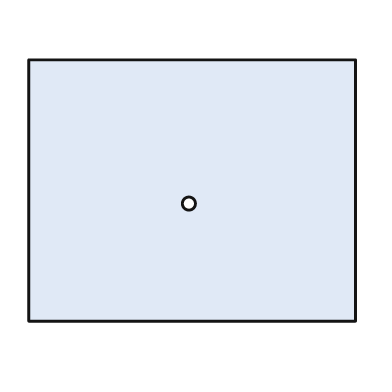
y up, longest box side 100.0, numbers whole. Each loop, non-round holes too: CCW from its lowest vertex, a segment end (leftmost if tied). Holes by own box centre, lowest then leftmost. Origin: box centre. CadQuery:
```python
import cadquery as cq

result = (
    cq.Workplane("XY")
    .moveTo(-50.0, -40.0)
    .lineTo(50.0, -40.0)
    .lineTo(50.0, 40.0)
    .lineTo(-50.0, 40.0)
    .close()
    .moveTo(-1.0, -4.0)
    .circle(2.0)
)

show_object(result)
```